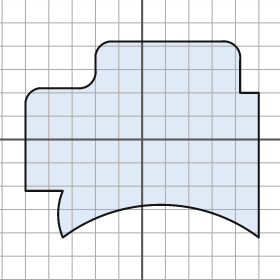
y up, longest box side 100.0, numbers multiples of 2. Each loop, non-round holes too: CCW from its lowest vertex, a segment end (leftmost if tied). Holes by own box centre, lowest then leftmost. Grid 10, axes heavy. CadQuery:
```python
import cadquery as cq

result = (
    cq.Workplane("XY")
    .moveTo(-34.0, -42.0)
    .threePointArc((8.0, -28.0), (50.0, -42.0))
    .lineTo(50.0, 20.0)
    .lineTo(42.0, 20.0)
    .lineTo(42.0, 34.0)
    .threePointArc((40.0, 40.0), (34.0, 42.0))
    .lineTo(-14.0, 42.0)
    .threePointArc((-18.0, 40.0), (-20.0, 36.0))
    .lineTo(-20.0, 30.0)
    .threePointArc((-22.0, 24.0), (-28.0, 22.0))
    .lineTo(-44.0, 22.0)
    .threePointArc((-48.0, 20.0), (-50.0, 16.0))
    .lineTo(-50.0, -22.0)
    .lineTo(-34.0, -22.0)
    .threePointArc((-36.0, -32.0), (-34.0, -42.0))
    .close()
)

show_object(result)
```